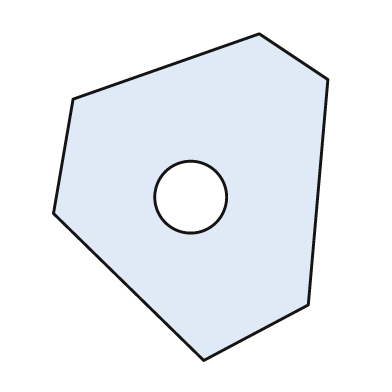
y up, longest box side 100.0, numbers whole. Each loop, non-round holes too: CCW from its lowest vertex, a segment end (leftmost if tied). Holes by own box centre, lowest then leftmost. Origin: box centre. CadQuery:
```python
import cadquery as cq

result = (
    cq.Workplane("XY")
    .moveTo(4.0, -50.0)
    .lineTo(36.0, -33.0)
    .lineTo(42.0, 36.0)
    .lineTo(21.0, 50.0)
    .lineTo(-36.0, 30.0)
    .lineTo(-42.0, -5.0)
    .close()
    .moveTo(0.0, 0.0)
    .circle(11.0)
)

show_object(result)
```